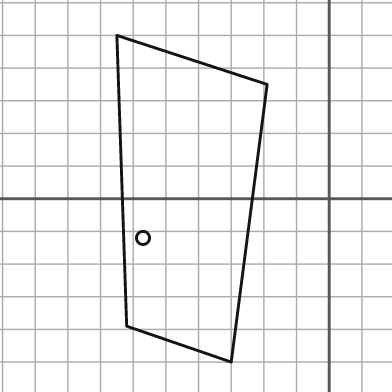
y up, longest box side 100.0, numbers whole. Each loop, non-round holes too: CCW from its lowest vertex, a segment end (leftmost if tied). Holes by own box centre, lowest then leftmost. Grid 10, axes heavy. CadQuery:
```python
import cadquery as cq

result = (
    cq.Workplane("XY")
    .moveTo(-30.0, -50.0)
    .lineTo(-19.0, 35.0)
    .lineTo(-65.0, 50.0)
    .lineTo(-62.0, -39.0)
    .close()
    .moveTo(-57.0, -12.0)
    .circle(2.0)
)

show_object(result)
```